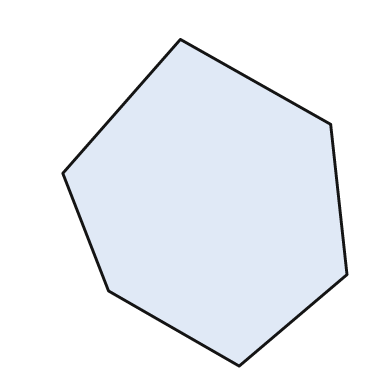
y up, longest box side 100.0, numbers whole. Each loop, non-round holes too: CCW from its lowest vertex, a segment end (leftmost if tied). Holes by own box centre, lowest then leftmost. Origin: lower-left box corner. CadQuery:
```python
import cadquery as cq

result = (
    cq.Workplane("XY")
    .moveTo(54.0, 0.0)
    .lineTo(87.0, 28.0)
    .lineTo(82.0, 74.0)
    .lineTo(36.0, 100.0)
    .lineTo(0.0, 59.0)
    .lineTo(14.0, 23.0)
    .close()
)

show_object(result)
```